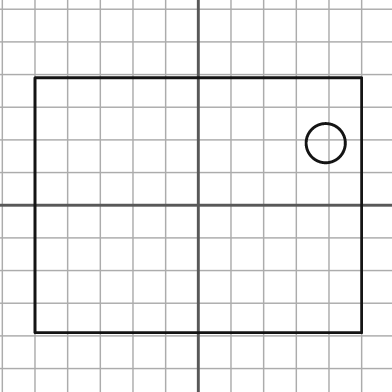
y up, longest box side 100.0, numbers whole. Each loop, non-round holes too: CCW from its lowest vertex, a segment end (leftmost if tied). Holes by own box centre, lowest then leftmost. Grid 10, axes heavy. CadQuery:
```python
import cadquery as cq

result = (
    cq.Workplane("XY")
    .moveTo(-50.0, -39.0)
    .lineTo(50.0, -39.0)
    .lineTo(50.0, 39.0)
    .lineTo(-50.0, 39.0)
    .close()
    .moveTo(39.0, 19.0)
    .circle(6.0)
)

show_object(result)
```